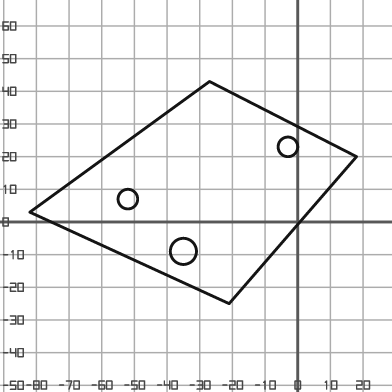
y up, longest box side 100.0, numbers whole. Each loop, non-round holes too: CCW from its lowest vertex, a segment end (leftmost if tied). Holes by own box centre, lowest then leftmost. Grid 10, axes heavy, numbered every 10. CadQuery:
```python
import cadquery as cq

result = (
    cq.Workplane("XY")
    .moveTo(-21.0, -25.0)
    .lineTo(18.0, 20.0)
    .lineTo(-27.0, 43.0)
    .lineTo(-82.0, 3.0)
    .close()
    .moveTo(-35.0, -9.0)
    .circle(4.0)
    .moveTo(-52.0, 7.0)
    .circle(3.0)
    .moveTo(-3.0, 23.0)
    .circle(3.0)
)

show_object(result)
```